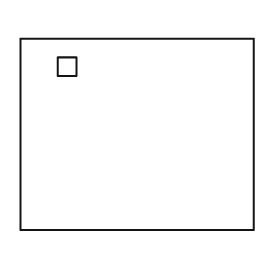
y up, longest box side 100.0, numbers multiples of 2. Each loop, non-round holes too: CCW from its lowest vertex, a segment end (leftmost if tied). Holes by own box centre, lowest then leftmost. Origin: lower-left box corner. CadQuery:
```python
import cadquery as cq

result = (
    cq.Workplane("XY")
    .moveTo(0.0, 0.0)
    .lineTo(100.0, 0.0)
    .lineTo(100.0, 82.0)
    .lineTo(0.0, 82.0)
    .close()
    .moveTo(16.0, 66.0)
    .lineTo(24.0, 66.0)
    .lineTo(24.0, 74.0)
    .lineTo(16.0, 74.0)
    .close()
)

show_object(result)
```